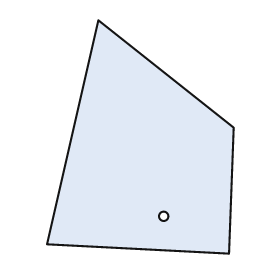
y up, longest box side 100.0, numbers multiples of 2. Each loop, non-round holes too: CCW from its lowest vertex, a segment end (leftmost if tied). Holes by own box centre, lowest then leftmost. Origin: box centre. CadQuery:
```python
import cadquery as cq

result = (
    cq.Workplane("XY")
    .moveTo(38.0, -50.0)
    .lineTo(40.0, 4.0)
    .lineTo(-18.0, 50.0)
    .lineTo(-40.0, -46.0)
    .close()
    .moveTo(10.0, -34.0)
    .circle(2.0)
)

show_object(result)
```